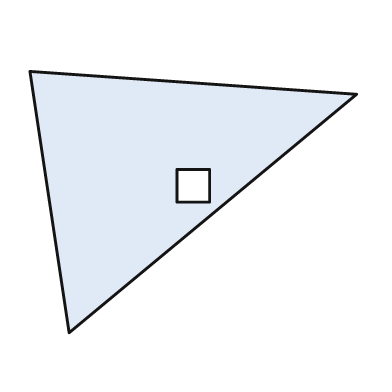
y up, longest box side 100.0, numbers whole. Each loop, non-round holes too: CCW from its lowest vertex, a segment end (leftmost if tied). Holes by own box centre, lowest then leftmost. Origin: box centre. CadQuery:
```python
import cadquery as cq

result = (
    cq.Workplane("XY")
    .moveTo(-38.0, -40.0)
    .lineTo(50.0, 33.0)
    .lineTo(-50.0, 40.0)
    .close()
    .moveTo(-5.0, 0.0)
    .lineTo(5.0, 0.0)
    .lineTo(5.0, 10.0)
    .lineTo(-5.0, 10.0)
    .close()
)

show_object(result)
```